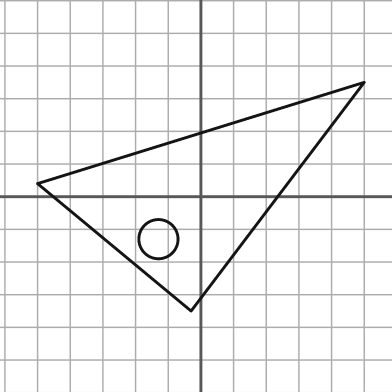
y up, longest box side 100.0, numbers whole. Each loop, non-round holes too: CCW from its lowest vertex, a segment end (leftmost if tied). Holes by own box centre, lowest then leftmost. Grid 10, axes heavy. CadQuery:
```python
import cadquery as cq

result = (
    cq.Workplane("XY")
    .moveTo(-3.0, -35.0)
    .lineTo(50.0, 35.0)
    .lineTo(-50.0, 4.0)
    .close()
    .moveTo(-13.0, -13.0)
    .circle(6.0)
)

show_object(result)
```